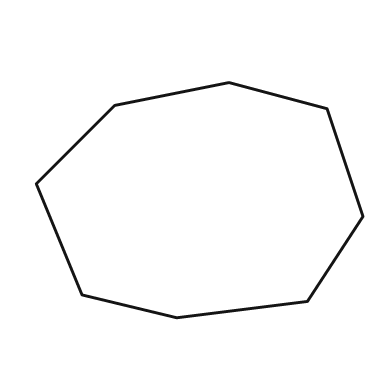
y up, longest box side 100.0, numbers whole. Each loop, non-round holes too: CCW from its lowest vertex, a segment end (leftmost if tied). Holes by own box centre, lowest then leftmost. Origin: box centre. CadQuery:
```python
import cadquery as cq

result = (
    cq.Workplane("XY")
    .moveTo(-7.0, -36.0)
    .lineTo(33.0, -31.0)
    .lineTo(50.0, -5.0)
    .lineTo(39.0, 28.0)
    .lineTo(9.0, 36.0)
    .lineTo(-26.0, 29.0)
    .lineTo(-50.0, 5.0)
    .lineTo(-36.0, -29.0)
    .close()
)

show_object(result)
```